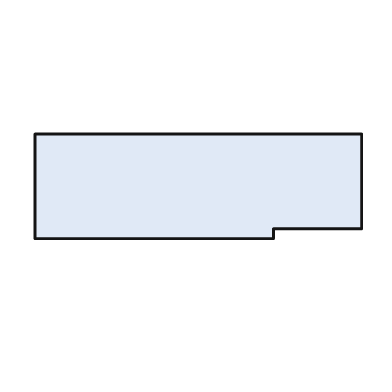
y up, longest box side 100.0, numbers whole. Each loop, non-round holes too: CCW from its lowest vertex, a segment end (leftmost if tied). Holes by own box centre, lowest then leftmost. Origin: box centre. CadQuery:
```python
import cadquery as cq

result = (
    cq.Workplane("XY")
    .moveTo(-50.0, -16.0)
    .lineTo(23.0, -16.0)
    .lineTo(23.0, -13.0)
    .lineTo(50.0, -13.0)
    .lineTo(50.0, 16.0)
    .lineTo(-50.0, 16.0)
    .close()
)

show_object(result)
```